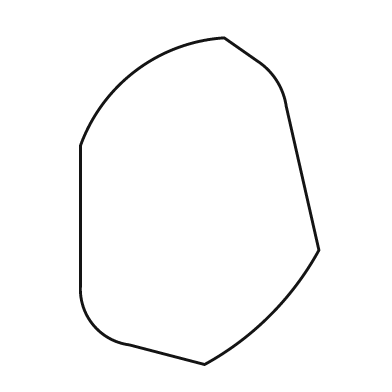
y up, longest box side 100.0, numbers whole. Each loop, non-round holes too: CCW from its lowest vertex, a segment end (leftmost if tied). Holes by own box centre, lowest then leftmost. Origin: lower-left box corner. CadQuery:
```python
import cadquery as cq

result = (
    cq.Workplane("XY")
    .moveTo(38.0, 0.0)
    .threePointArc((58.0, 15.0), (73.0, 35.0))
    .lineTo(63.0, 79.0)
    .threePointArc((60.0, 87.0), (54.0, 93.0))
    .lineTo(44.0, 100.0)
    .threePointArc((17.0, 90.0), (0.0, 67.0))
    .lineTo(0.0, 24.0)
    .threePointArc((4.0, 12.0), (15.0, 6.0))
    .close()
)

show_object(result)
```